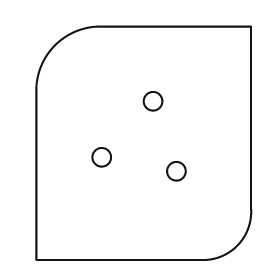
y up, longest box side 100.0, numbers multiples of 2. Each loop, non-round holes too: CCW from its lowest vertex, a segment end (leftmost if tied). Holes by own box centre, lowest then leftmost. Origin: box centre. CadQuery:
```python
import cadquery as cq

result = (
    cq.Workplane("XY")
    .moveTo(-46.0, -50.0)
    .lineTo(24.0, -50.0)
    .threePointArc((40.0, -44.0), (46.0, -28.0))
    .lineTo(46.0, 50.0)
    .lineTo(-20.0, 50.0)
    .threePointArc((-38.0, 42.0), (-46.0, 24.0))
    .close()
    .moveTo(14.0, -12.0)
    .circle(4.0)
    .moveTo(-18.0, -6.0)
    .circle(4.0)
    .moveTo(4.0, 18.0)
    .circle(4.0)
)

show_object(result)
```